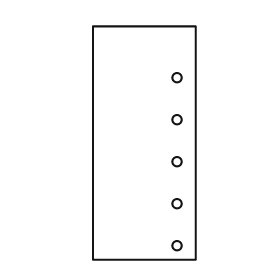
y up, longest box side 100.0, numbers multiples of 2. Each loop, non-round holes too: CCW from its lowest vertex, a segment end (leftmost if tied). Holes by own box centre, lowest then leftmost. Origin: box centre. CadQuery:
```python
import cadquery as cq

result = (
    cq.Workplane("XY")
    .moveTo(-22.0, -50.0)
    .lineTo(22.0, -50.0)
    .lineTo(22.0, 50.0)
    .lineTo(-22.0, 50.0)
    .close()
    .moveTo(14.0, -44.0)
    .circle(2.0)
    .moveTo(14.0, -26.0)
    .circle(2.0)
    .moveTo(14.0, -8.0)
    .circle(2.0)
    .moveTo(14.0, 10.0)
    .circle(2.0)
    .moveTo(14.0, 28.0)
    .circle(2.0)
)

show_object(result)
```